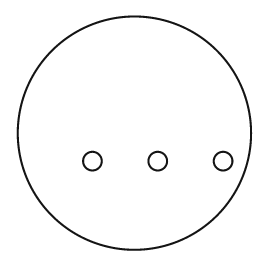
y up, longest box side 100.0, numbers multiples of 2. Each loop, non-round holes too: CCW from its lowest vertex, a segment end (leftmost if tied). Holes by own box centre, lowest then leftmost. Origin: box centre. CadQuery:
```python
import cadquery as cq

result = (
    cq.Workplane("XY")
    .moveTo(0.0, 0.0)
    .circle(50.0)
    .moveTo(-18.0, -12.0)
    .circle(4.0)
    .moveTo(10.0, -12.0)
    .circle(4.0)
    .moveTo(38.0, -12.0)
    .circle(4.0)
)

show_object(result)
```